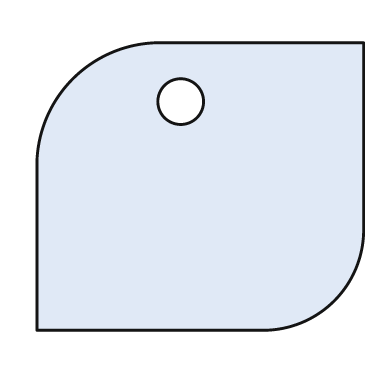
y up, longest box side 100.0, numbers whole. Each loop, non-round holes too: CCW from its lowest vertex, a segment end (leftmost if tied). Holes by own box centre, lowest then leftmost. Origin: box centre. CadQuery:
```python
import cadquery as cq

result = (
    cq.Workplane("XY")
    .moveTo(-50.0, -44.0)
    .lineTo(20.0, -44.0)
    .threePointArc((41.0, -35.0), (50.0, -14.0))
    .lineTo(50.0, 44.0)
    .lineTo(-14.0, 44.0)
    .threePointArc((-39.0, 33.0), (-50.0, 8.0))
    .close()
    .moveTo(-6.0, 26.0)
    .circle(7.0)
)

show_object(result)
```